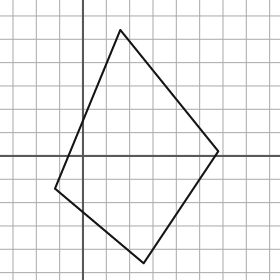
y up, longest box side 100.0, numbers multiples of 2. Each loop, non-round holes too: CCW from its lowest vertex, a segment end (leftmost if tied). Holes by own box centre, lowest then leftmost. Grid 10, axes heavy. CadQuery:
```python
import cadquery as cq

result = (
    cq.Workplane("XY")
    .moveTo(26.0, -46.0)
    .lineTo(58.0, 2.0)
    .lineTo(16.0, 54.0)
    .lineTo(-12.0, -14.0)
    .close()
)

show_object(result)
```